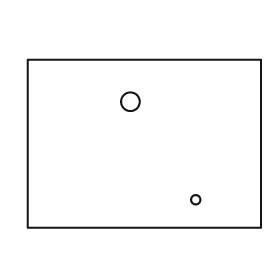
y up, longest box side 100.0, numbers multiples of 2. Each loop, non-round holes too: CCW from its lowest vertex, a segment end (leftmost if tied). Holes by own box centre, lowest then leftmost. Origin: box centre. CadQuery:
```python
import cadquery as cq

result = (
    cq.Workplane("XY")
    .moveTo(-50.0, -36.0)
    .lineTo(50.0, -36.0)
    .lineTo(50.0, 36.0)
    .lineTo(-50.0, 36.0)
    .close()
    .moveTo(22.0, -24.0)
    .circle(2.0)
    .moveTo(-6.0, 18.0)
    .circle(4.0)
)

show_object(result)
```